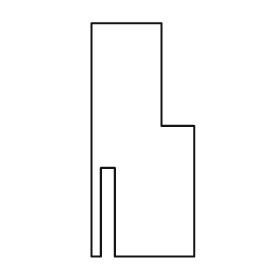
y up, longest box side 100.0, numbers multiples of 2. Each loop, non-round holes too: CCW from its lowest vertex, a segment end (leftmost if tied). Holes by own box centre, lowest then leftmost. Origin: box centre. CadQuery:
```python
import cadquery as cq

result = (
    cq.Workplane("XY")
    .moveTo(-22.0, -50.0)
    .lineTo(-18.0, -50.0)
    .lineTo(-18.0, -12.0)
    .lineTo(-12.0, -12.0)
    .lineTo(-12.0, -50.0)
    .lineTo(22.0, -50.0)
    .lineTo(22.0, 6.0)
    .lineTo(8.0, 6.0)
    .lineTo(8.0, 50.0)
    .lineTo(-22.0, 50.0)
    .close()
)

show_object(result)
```